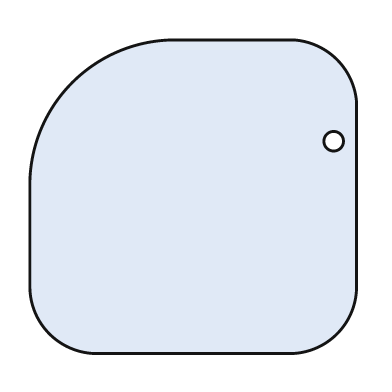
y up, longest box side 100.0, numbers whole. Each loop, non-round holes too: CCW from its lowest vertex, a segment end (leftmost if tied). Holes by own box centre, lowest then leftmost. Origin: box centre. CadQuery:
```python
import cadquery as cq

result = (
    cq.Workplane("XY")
    .moveTo(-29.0, -48.0)
    .lineTo(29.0, -48.0)
    .threePointArc((44.0, -42.0), (50.0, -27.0))
    .lineTo(50.0, 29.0)
    .threePointArc((44.0, 42.0), (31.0, 48.0))
    .lineTo(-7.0, 48.0)
    .threePointArc((-37.0, 35.0), (-50.0, 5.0))
    .lineTo(-50.0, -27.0)
    .threePointArc((-44.0, -42.0), (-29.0, -48.0))
    .close()
    .moveTo(43.0, 17.0)
    .circle(3.0)
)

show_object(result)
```